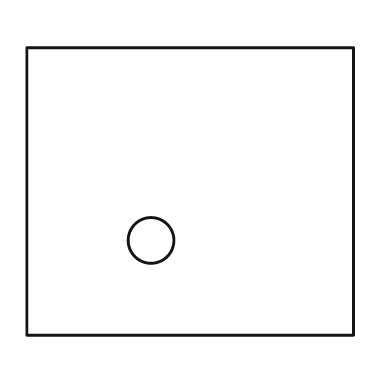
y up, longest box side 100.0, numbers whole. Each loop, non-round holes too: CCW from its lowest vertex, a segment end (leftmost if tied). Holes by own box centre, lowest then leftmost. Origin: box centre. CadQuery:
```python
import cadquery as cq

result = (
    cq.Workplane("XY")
    .moveTo(-50.0, -44.0)
    .lineTo(50.0, -44.0)
    .lineTo(50.0, 44.0)
    .lineTo(-50.0, 44.0)
    .close()
    .moveTo(-12.0, -15.0)
    .circle(7.0)
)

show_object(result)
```